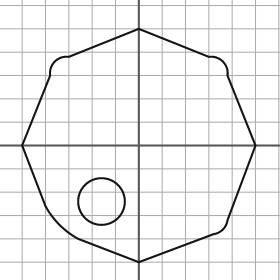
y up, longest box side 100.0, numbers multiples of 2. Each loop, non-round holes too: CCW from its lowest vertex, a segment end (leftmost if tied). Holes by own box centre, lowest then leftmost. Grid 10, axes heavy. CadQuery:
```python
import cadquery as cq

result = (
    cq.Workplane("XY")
    .moveTo(0.0, -50.0)
    .lineTo(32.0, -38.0)
    .threePointArc((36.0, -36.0), (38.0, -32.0))
    .lineTo(50.0, 0.0)
    .lineTo(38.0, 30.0)
    .threePointArc((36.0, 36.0), (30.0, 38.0))
    .lineTo(0.0, 50.0)
    .lineTo(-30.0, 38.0)
    .threePointArc((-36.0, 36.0), (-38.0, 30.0))
    .lineTo(-50.0, 0.0)
    .lineTo(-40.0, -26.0)
    .threePointArc((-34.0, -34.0), (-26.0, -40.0))
    .close()
    .moveTo(-16.0, -24.0)
    .circle(10.0)
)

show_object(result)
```